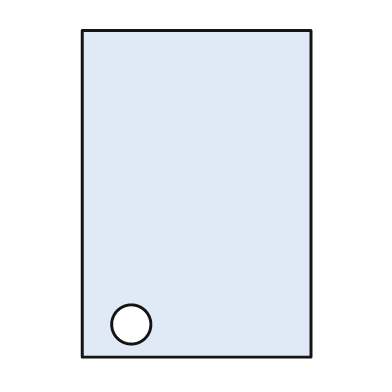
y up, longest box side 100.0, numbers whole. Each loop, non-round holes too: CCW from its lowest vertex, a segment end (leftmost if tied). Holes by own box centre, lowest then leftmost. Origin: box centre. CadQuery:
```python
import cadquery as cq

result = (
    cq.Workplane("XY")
    .moveTo(-35.0, -50.0)
    .lineTo(35.0, -50.0)
    .lineTo(35.0, 50.0)
    .lineTo(-35.0, 50.0)
    .close()
    .moveTo(-20.0, -40.0)
    .circle(6.0)
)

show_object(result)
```